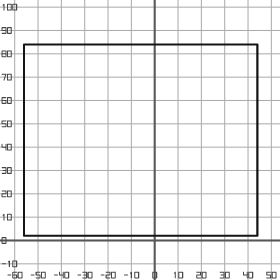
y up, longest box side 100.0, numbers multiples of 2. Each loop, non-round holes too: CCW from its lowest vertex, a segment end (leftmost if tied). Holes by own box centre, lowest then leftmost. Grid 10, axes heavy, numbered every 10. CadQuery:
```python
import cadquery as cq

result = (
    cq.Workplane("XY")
    .moveTo(-56.0, 2.0)
    .lineTo(44.0, 2.0)
    .lineTo(44.0, 84.0)
    .lineTo(-56.0, 84.0)
    .close()
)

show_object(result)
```